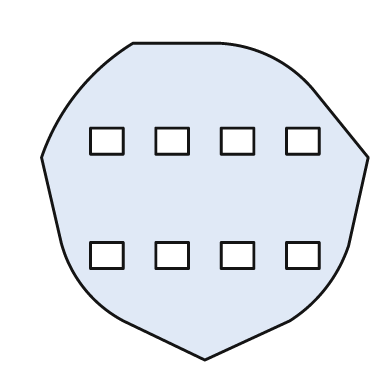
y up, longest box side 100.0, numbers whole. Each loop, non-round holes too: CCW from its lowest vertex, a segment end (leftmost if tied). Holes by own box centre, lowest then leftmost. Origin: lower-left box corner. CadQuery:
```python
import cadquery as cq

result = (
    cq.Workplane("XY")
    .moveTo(50.0, 0.0)
    .lineTo(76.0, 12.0)
    .threePointArc((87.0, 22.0), (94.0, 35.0))
    .lineTo(100.0, 62.0)
    .lineTo(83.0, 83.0)
    .threePointArc((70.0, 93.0), (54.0, 97.0))
    .lineTo(28.0, 97.0)
    .threePointArc((11.0, 82.0), (0.0, 62.0))
    .lineTo(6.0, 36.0)
    .threePointArc((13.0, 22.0), (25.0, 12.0))
    .close()
    .moveTo(15.0, 28.0)
    .lineTo(25.0, 28.0)
    .lineTo(25.0, 36.0)
    .lineTo(15.0, 36.0)
    .close()
    .moveTo(35.0, 28.0)
    .lineTo(45.0, 28.0)
    .lineTo(45.0, 36.0)
    .lineTo(35.0, 36.0)
    .close()
    .moveTo(55.0, 28.0)
    .lineTo(65.0, 28.0)
    .lineTo(65.0, 36.0)
    .lineTo(55.0, 36.0)
    .close()
    .moveTo(75.0, 28.0)
    .lineTo(85.0, 28.0)
    .lineTo(85.0, 36.0)
    .lineTo(75.0, 36.0)
    .close()
    .moveTo(15.0, 63.0)
    .lineTo(25.0, 63.0)
    .lineTo(25.0, 71.0)
    .lineTo(15.0, 71.0)
    .close()
    .moveTo(35.0, 63.0)
    .lineTo(45.0, 63.0)
    .lineTo(45.0, 71.0)
    .lineTo(35.0, 71.0)
    .close()
    .moveTo(55.0, 63.0)
    .lineTo(65.0, 63.0)
    .lineTo(65.0, 71.0)
    .lineTo(55.0, 71.0)
    .close()
    .moveTo(75.0, 63.0)
    .lineTo(85.0, 63.0)
    .lineTo(85.0, 71.0)
    .lineTo(75.0, 71.0)
    .close()
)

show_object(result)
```